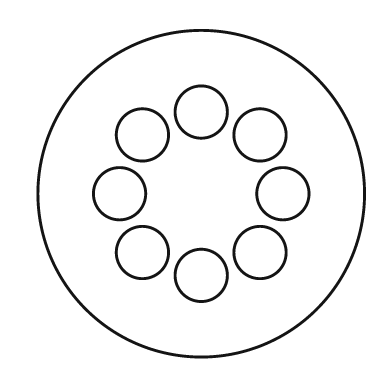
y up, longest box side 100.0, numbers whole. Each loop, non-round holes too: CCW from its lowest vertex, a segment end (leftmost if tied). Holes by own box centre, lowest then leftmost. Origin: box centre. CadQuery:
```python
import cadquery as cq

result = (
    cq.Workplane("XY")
    .moveTo(0.0, 0.0)
    .circle(50.0)
    .moveTo(0.0, -25.0)
    .circle(8.0)
    .moveTo(-18.0, -18.0)
    .circle(8.0)
    .moveTo(18.0, -18.0)
    .circle(8.0)
    .moveTo(-25.0, 0.0)
    .circle(8.0)
    .moveTo(25.0, 0.0)
    .circle(8.0)
    .moveTo(-18.0, 18.0)
    .circle(8.0)
    .moveTo(18.0, 18.0)
    .circle(8.0)
    .moveTo(0.0, 25.0)
    .circle(8.0)
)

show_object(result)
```